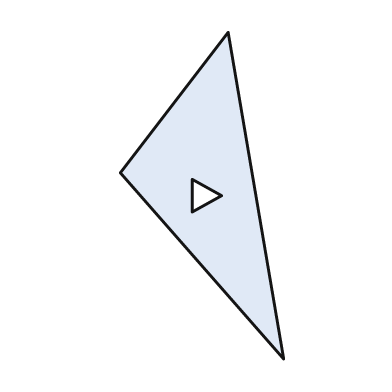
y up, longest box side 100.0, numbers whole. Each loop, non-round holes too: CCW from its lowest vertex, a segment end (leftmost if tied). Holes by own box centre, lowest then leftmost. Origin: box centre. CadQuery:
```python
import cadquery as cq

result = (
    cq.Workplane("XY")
    .moveTo(25.0, -50.0)
    .lineTo(8.0, 50.0)
    .lineTo(-25.0, 7.0)
    .close()
    .moveTo(-3.0, -5.0)
    .lineTo(6.0, 0.0)
    .lineTo(-3.0, 5.0)
    .close()
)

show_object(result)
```